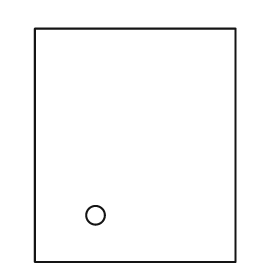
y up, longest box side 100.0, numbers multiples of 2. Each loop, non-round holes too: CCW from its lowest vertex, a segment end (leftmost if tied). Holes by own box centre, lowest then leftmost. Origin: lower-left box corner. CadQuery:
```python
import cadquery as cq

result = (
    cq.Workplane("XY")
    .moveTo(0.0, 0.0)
    .lineTo(86.0, 0.0)
    .lineTo(86.0, 100.0)
    .lineTo(0.0, 100.0)
    .close()
    .moveTo(26.0, 20.0)
    .circle(4.0)
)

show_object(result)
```